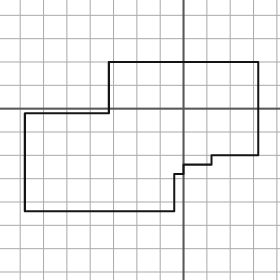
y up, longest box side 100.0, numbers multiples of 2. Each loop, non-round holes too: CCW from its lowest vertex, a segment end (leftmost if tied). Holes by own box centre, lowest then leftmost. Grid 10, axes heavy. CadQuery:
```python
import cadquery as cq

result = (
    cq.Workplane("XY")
    .moveTo(-68.0, -44.0)
    .lineTo(-4.0, -44.0)
    .lineTo(-4.0, -28.0)
    .lineTo(0.0, -28.0)
    .lineTo(0.0, -24.0)
    .lineTo(12.0, -24.0)
    .lineTo(12.0, -20.0)
    .lineTo(32.0, -20.0)
    .lineTo(32.0, 20.0)
    .lineTo(-32.0, 20.0)
    .lineTo(-32.0, -2.0)
    .lineTo(-68.0, -2.0)
    .close()
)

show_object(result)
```